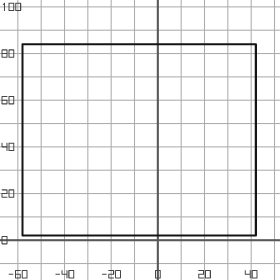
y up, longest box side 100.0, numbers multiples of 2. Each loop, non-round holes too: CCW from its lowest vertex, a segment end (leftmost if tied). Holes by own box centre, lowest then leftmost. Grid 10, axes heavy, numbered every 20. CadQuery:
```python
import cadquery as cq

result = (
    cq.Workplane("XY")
    .moveTo(-58.0, 2.0)
    .lineTo(42.0, 2.0)
    .lineTo(42.0, 84.0)
    .lineTo(-58.0, 84.0)
    .close()
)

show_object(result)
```